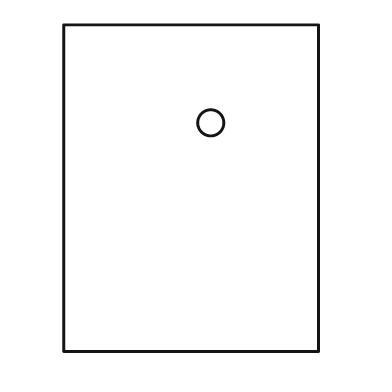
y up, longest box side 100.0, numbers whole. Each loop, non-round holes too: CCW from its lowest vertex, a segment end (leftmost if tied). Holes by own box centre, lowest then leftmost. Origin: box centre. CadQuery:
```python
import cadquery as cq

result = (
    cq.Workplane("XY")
    .moveTo(-39.0, -50.0)
    .lineTo(39.0, -50.0)
    .lineTo(39.0, 50.0)
    .lineTo(-39.0, 50.0)
    .close()
    .moveTo(6.0, 20.0)
    .circle(4.0)
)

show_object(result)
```